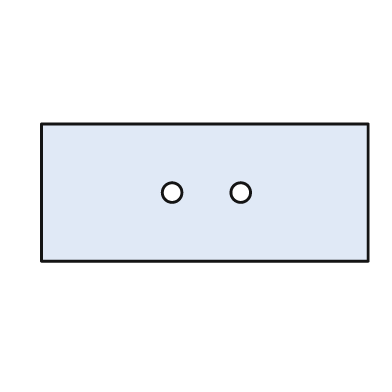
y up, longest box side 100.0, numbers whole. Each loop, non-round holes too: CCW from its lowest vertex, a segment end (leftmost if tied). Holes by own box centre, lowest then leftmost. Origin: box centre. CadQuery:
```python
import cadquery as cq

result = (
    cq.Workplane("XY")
    .moveTo(-50.0, -21.0)
    .lineTo(50.0, -21.0)
    .lineTo(50.0, 21.0)
    .lineTo(-50.0, 21.0)
    .close()
    .moveTo(-10.0, 0.0)
    .circle(3.0)
    .moveTo(11.0, 0.0)
    .circle(3.0)
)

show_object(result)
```